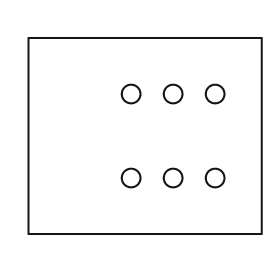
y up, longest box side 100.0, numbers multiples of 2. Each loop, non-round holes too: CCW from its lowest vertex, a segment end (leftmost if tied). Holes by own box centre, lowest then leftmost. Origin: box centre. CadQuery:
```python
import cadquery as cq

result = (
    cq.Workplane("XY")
    .moveTo(-50.0, -42.0)
    .lineTo(50.0, -42.0)
    .lineTo(50.0, 42.0)
    .lineTo(-50.0, 42.0)
    .close()
    .moveTo(-6.0, -18.0)
    .circle(4.0)
    .moveTo(12.0, -18.0)
    .circle(4.0)
    .moveTo(30.0, -18.0)
    .circle(4.0)
    .moveTo(-6.0, 18.0)
    .circle(4.0)
    .moveTo(12.0, 18.0)
    .circle(4.0)
    .moveTo(30.0, 18.0)
    .circle(4.0)
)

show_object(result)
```